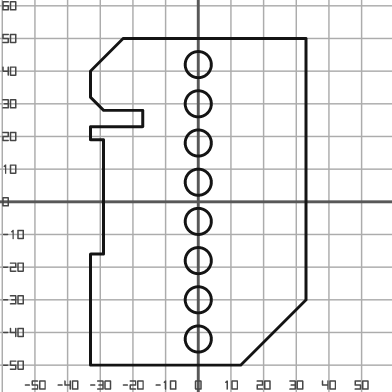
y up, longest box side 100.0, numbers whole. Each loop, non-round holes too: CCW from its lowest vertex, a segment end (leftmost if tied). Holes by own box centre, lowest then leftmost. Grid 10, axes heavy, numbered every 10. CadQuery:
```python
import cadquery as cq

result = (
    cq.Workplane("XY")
    .moveTo(-33.0, -50.0)
    .lineTo(13.0, -50.0)
    .lineTo(33.0, -30.0)
    .lineTo(33.0, 50.0)
    .lineTo(-23.0, 50.0)
    .lineTo(-33.0, 40.0)
    .lineTo(-33.0, 32.0)
    .lineTo(-29.0, 28.0)
    .lineTo(-17.0, 28.0)
    .lineTo(-17.0, 23.0)
    .lineTo(-33.0, 23.0)
    .lineTo(-33.0, 19.0)
    .lineTo(-29.0, 19.0)
    .lineTo(-29.0, -16.0)
    .lineTo(-33.0, -16.0)
    .close()
    .moveTo(0.0, -42.0)
    .circle(4.0)
    .moveTo(0.0, -30.0)
    .circle(4.0)
    .moveTo(0.0, -18.0)
    .circle(4.0)
    .moveTo(0.0, -6.0)
    .circle(4.0)
    .moveTo(0.0, 6.0)
    .circle(4.0)
    .moveTo(0.0, 18.0)
    .circle(4.0)
    .moveTo(0.0, 30.0)
    .circle(4.0)
    .moveTo(0.0, 42.0)
    .circle(4.0)
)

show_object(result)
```